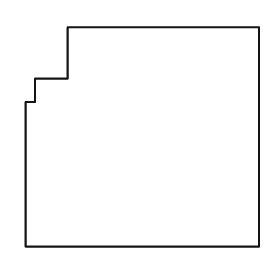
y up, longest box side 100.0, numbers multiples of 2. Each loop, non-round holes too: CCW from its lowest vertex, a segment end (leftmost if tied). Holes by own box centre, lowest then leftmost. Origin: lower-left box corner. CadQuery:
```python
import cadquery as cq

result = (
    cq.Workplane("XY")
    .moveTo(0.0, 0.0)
    .lineTo(100.0, 0.0)
    .lineTo(100.0, 94.0)
    .lineTo(18.0, 94.0)
    .lineTo(18.0, 72.0)
    .lineTo(4.0, 72.0)
    .lineTo(4.0, 62.0)
    .lineTo(0.0, 62.0)
    .close()
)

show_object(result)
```